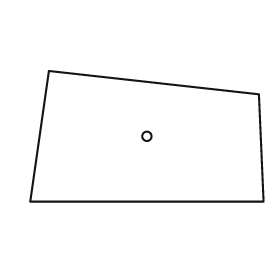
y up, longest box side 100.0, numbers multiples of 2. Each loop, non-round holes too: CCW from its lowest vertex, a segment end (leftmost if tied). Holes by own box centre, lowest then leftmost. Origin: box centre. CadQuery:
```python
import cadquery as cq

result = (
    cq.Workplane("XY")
    .moveTo(-50.0, -28.0)
    .lineTo(50.0, -28.0)
    .lineTo(48.0, 18.0)
    .lineTo(-42.0, 28.0)
    .close()
    .moveTo(0.0, 0.0)
    .circle(2.0)
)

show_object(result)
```